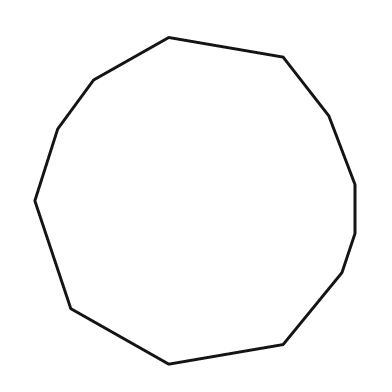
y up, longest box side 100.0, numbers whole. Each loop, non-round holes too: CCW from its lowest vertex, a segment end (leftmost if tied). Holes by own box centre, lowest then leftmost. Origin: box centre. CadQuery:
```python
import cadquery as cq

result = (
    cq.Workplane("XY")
    .moveTo(-8.0, -50.0)
    .lineTo(27.0, -44.0)
    .lineTo(45.0, -22.0)
    .lineTo(49.0, -10.0)
    .lineTo(49.0, 5.0)
    .lineTo(41.0, 26.0)
    .lineTo(27.0, 44.0)
    .lineTo(-8.0, 50.0)
    .lineTo(-31.0, 37.0)
    .lineTo(-42.0, 22.0)
    .lineTo(-49.0, 0.0)
    .lineTo(-38.0, -33.0)
    .close()
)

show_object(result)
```